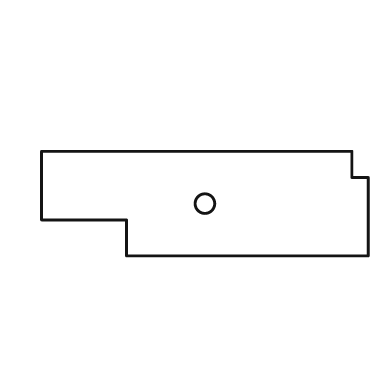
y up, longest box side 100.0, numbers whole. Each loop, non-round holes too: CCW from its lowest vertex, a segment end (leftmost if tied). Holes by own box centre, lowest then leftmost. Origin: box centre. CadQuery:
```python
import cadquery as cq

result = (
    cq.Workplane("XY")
    .moveTo(-24.0, -16.0)
    .lineTo(50.0, -16.0)
    .lineTo(50.0, 8.0)
    .lineTo(45.0, 8.0)
    .lineTo(45.0, 16.0)
    .lineTo(-50.0, 16.0)
    .lineTo(-50.0, -5.0)
    .lineTo(-24.0, -5.0)
    .close()
    .moveTo(0.0, 0.0)
    .circle(3.0)
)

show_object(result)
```